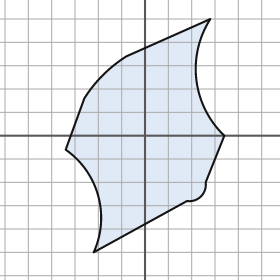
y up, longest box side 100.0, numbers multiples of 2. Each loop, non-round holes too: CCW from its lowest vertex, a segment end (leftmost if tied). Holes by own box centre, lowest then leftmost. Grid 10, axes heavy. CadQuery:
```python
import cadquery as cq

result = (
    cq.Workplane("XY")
    .moveTo(-22.0, -50.0)
    .lineTo(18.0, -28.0)
    .threePointArc((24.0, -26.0), (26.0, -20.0))
    .lineTo(34.0, 0.0)
    .threePointArc((22.0, 24.0), (28.0, 50.0))
    .lineTo(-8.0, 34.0)
    .threePointArc((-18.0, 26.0), (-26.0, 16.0))
    .lineTo(-34.0, -6.0)
    .threePointArc((-20.0, -26.0), (-22.0, -50.0))
    .close()
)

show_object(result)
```